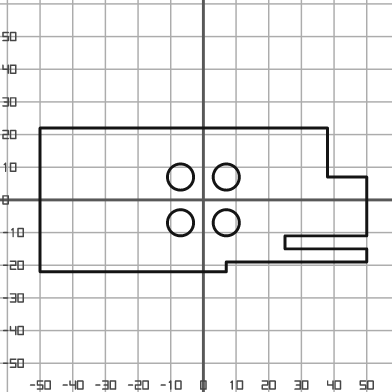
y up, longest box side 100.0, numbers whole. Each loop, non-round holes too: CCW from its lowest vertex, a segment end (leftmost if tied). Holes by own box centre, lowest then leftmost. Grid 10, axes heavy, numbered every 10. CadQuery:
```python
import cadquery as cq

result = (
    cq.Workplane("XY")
    .moveTo(-50.0, -22.0)
    .lineTo(7.0, -22.0)
    .lineTo(7.0, -19.0)
    .lineTo(50.0, -19.0)
    .lineTo(50.0, -15.0)
    .lineTo(25.0, -15.0)
    .lineTo(25.0, -11.0)
    .lineTo(50.0, -11.0)
    .lineTo(50.0, 7.0)
    .lineTo(38.0, 7.0)
    .lineTo(38.0, 22.0)
    .lineTo(-50.0, 22.0)
    .close()
    .moveTo(-7.0, -7.0)
    .circle(4.0)
    .moveTo(7.0, -7.0)
    .circle(4.0)
    .moveTo(-7.0, 7.0)
    .circle(4.0)
    .moveTo(7.0, 7.0)
    .circle(4.0)
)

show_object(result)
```